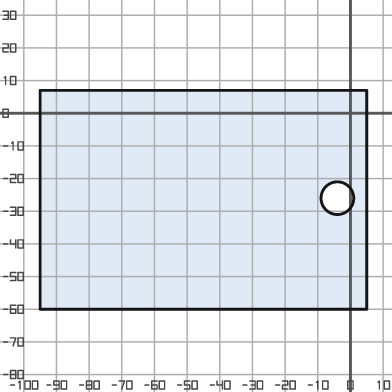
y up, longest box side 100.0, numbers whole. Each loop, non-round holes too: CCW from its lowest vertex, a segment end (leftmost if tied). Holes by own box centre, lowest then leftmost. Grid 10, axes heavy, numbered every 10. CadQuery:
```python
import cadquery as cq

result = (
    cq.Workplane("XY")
    .moveTo(-95.0, -60.0)
    .lineTo(5.0, -60.0)
    .lineTo(5.0, 7.0)
    .lineTo(-95.0, 7.0)
    .close()
    .moveTo(-4.0, -26.0)
    .circle(5.0)
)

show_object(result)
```